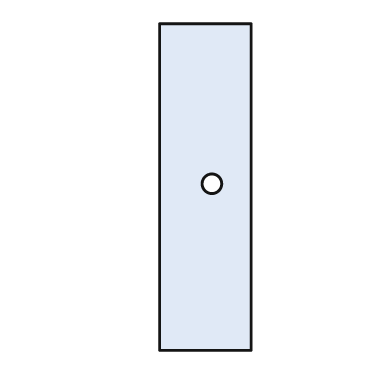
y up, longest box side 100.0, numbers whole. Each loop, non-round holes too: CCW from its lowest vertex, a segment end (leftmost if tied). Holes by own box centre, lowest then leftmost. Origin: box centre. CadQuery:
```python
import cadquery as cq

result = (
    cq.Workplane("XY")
    .moveTo(-14.0, -50.0)
    .lineTo(14.0, -50.0)
    .lineTo(14.0, 50.0)
    .lineTo(-14.0, 50.0)
    .close()
    .moveTo(2.0, 1.0)
    .circle(3.0)
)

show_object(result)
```